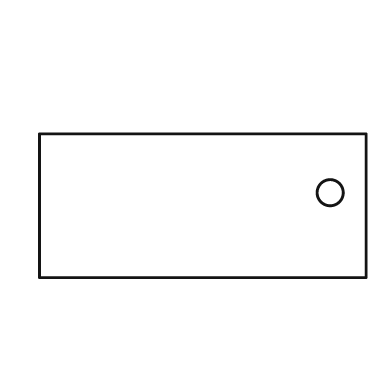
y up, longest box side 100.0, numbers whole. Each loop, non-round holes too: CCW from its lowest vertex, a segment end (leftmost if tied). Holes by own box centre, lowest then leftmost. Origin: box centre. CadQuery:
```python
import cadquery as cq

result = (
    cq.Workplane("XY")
    .moveTo(-50.0, -22.0)
    .lineTo(50.0, -22.0)
    .lineTo(50.0, 22.0)
    .lineTo(-50.0, 22.0)
    .close()
    .moveTo(39.0, 4.0)
    .circle(4.0)
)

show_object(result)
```